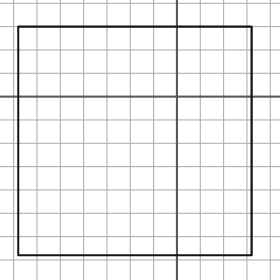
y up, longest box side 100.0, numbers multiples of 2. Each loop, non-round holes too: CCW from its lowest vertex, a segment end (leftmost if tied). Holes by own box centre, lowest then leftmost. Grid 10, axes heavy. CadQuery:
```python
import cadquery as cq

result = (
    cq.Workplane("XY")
    .moveTo(-68.0, -68.0)
    .lineTo(32.0, -68.0)
    .lineTo(32.0, 30.0)
    .lineTo(-68.0, 30.0)
    .close()
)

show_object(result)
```